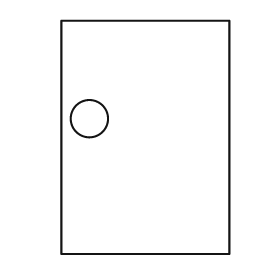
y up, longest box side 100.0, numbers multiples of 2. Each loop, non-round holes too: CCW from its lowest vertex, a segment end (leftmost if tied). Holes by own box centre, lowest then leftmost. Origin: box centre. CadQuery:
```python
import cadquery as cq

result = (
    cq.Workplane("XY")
    .moveTo(-36.0, -50.0)
    .lineTo(36.0, -50.0)
    .lineTo(36.0, 50.0)
    .lineTo(-36.0, 50.0)
    .close()
    .moveTo(-24.0, 8.0)
    .circle(8.0)
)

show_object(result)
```